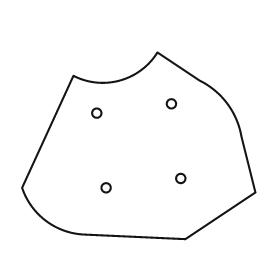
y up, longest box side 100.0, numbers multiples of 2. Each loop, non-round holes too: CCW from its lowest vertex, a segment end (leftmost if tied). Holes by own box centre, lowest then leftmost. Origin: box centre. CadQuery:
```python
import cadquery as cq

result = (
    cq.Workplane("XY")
    .moveTo(20.0, -40.0)
    .lineTo(50.0, -20.0)
    .lineTo(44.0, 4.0)
    .threePointArc((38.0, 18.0), (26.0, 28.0))
    .lineTo(8.0, 40.0)
    .threePointArc((-8.0, 28.0), (-28.0, 30.0))
    .lineTo(-50.0, -18.0)
    .threePointArc((-40.0, -32.0), (-24.0, -38.0))
    .close()
    .moveTo(-14.0, -18.0)
    .circle(2.0)
    .moveTo(18.0, -14.0)
    .circle(2.0)
    .moveTo(-18.0, 14.0)
    .circle(2.0)
    .moveTo(14.0, 18.0)
    .circle(2.0)
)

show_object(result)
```